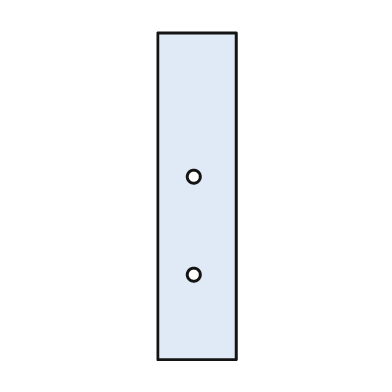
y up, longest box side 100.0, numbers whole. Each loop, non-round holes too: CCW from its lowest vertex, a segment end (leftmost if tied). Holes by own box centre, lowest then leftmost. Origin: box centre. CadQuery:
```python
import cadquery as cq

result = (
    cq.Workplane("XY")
    .moveTo(-12.0, -50.0)
    .lineTo(12.0, -50.0)
    .lineTo(12.0, 50.0)
    .lineTo(-12.0, 50.0)
    .close()
    .moveTo(-1.0, -24.0)
    .circle(2.0)
    .moveTo(-1.0, 6.0)
    .circle(2.0)
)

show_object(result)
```